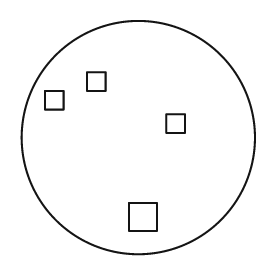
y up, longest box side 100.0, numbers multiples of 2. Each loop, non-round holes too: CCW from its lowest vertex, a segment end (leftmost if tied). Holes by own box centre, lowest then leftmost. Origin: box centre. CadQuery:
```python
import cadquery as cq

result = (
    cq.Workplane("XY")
    .moveTo(0.0, 0.0)
    .circle(50.0)
    .moveTo(-4.0, -40.0)
    .lineTo(8.0, -40.0)
    .lineTo(8.0, -28.0)
    .lineTo(-4.0, -28.0)
    .close()
    .moveTo(12.0, 2.0)
    .lineTo(20.0, 2.0)
    .lineTo(20.0, 10.0)
    .lineTo(12.0, 10.0)
    .close()
    .moveTo(-40.0, 12.0)
    .lineTo(-32.0, 12.0)
    .lineTo(-32.0, 20.0)
    .lineTo(-40.0, 20.0)
    .close()
    .moveTo(-22.0, 20.0)
    .lineTo(-14.0, 20.0)
    .lineTo(-14.0, 28.0)
    .lineTo(-22.0, 28.0)
    .close()
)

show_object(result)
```